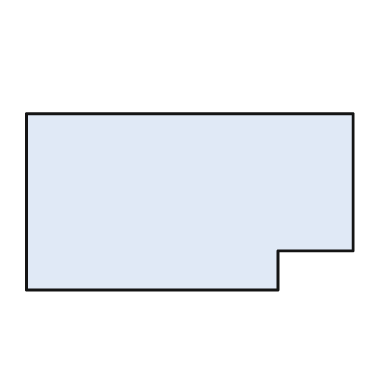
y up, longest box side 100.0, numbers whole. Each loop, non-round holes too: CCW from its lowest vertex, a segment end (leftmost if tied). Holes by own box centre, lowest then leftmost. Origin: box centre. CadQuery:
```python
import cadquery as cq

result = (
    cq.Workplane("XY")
    .moveTo(-50.0, -27.0)
    .lineTo(27.0, -27.0)
    .lineTo(27.0, -15.0)
    .lineTo(50.0, -15.0)
    .lineTo(50.0, 27.0)
    .lineTo(-50.0, 27.0)
    .close()
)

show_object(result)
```